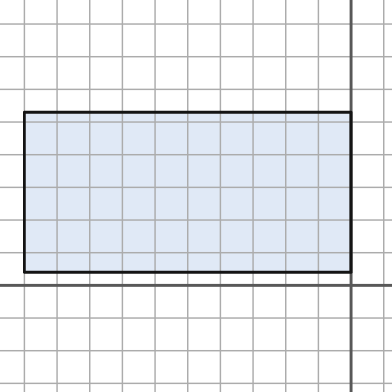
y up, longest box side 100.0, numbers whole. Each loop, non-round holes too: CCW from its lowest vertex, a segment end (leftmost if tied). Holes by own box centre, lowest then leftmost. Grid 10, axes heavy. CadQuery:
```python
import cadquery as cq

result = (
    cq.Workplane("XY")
    .moveTo(-100.0, 4.0)
    .lineTo(0.0, 4.0)
    .lineTo(0.0, 53.0)
    .lineTo(-100.0, 53.0)
    .close()
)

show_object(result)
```